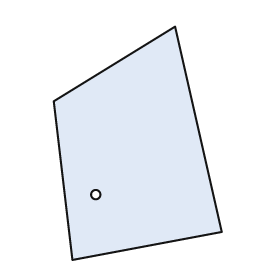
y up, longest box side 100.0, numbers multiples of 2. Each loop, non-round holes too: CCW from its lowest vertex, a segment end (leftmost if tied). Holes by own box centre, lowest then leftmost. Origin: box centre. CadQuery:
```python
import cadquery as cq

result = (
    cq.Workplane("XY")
    .moveTo(-28.0, -50.0)
    .lineTo(36.0, -38.0)
    .lineTo(16.0, 50.0)
    .lineTo(-36.0, 18.0)
    .close()
    .moveTo(-18.0, -22.0)
    .circle(2.0)
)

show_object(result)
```